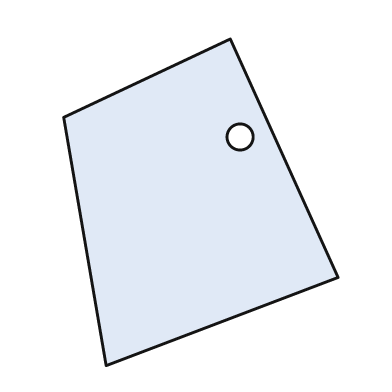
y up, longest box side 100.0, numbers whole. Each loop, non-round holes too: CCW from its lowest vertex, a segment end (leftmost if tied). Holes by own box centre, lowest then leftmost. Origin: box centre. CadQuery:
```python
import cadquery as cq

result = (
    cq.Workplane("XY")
    .moveTo(-29.0, -50.0)
    .lineTo(42.0, -23.0)
    .lineTo(9.0, 50.0)
    .lineTo(-42.0, 26.0)
    .close()
    .moveTo(12.0, 20.0)
    .circle(4.0)
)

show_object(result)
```